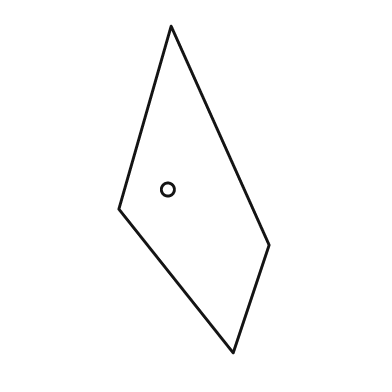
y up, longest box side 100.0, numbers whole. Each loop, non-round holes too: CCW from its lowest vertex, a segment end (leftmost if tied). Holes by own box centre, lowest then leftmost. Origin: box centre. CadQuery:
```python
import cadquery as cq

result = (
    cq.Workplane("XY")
    .moveTo(12.0, -50.0)
    .lineTo(23.0, -17.0)
    .lineTo(-7.0, 50.0)
    .lineTo(-23.0, -6.0)
    .close()
    .moveTo(-8.0, 0.0)
    .circle(2.0)
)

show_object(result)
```